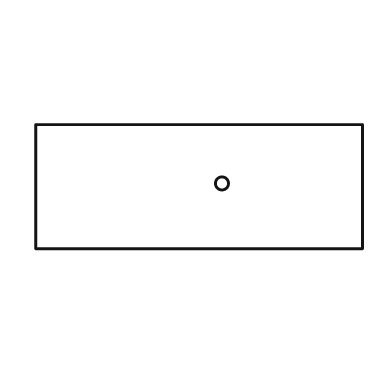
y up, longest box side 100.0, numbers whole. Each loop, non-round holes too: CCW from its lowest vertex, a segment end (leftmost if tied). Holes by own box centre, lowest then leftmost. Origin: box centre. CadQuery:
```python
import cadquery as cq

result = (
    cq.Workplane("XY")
    .moveTo(-50.0, -19.0)
    .lineTo(50.0, -19.0)
    .lineTo(50.0, 19.0)
    .lineTo(-50.0, 19.0)
    .close()
    .moveTo(7.0, 1.0)
    .circle(2.0)
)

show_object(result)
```